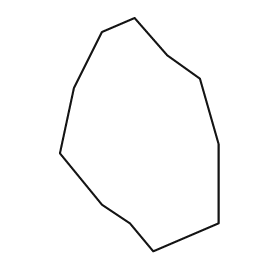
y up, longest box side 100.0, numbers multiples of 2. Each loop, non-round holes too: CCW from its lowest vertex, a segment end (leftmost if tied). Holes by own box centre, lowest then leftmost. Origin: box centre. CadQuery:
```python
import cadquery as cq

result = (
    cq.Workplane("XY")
    .moveTo(6.0, -50.0)
    .lineTo(34.0, -38.0)
    .lineTo(34.0, -4.0)
    .lineTo(26.0, 24.0)
    .lineTo(12.0, 34.0)
    .lineTo(-2.0, 50.0)
    .lineTo(-16.0, 44.0)
    .lineTo(-28.0, 20.0)
    .lineTo(-34.0, -8.0)
    .lineTo(-16.0, -30.0)
    .lineTo(-4.0, -38.0)
    .close()
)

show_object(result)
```